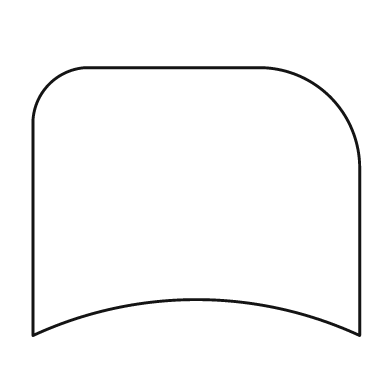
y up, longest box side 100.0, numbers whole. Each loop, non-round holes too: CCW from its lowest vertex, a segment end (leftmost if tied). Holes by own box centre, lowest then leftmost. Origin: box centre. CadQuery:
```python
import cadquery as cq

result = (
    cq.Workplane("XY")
    .moveTo(-50.0, -41.0)
    .threePointArc((0.0, -30.0), (50.0, -41.0))
    .lineTo(50.0, 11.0)
    .threePointArc((41.0, 32.0), (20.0, 41.0))
    .lineTo(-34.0, 41.0)
    .threePointArc((-45.0, 36.0), (-50.0, 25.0))
    .close()
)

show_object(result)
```